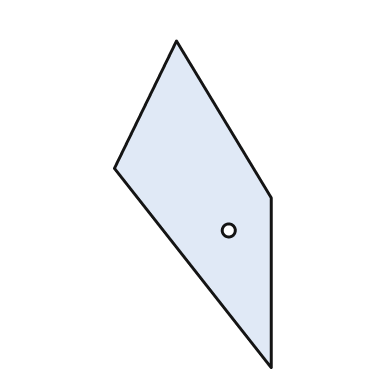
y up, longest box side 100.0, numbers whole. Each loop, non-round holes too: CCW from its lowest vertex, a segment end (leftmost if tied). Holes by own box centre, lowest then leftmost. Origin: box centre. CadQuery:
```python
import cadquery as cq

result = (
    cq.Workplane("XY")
    .moveTo(24.0, -50.0)
    .lineTo(24.0, 2.0)
    .lineTo(-5.0, 50.0)
    .lineTo(-24.0, 11.0)
    .close()
    .moveTo(11.0, -8.0)
    .circle(2.0)
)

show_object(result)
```